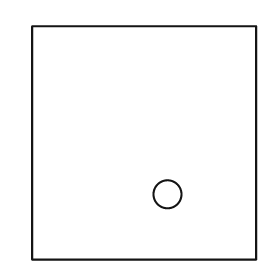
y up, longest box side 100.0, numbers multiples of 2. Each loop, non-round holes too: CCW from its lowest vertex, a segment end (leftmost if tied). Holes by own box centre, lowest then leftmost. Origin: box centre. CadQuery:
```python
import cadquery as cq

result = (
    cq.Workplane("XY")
    .moveTo(-48.0, -50.0)
    .lineTo(48.0, -50.0)
    .lineTo(48.0, 50.0)
    .lineTo(-48.0, 50.0)
    .close()
    .moveTo(10.0, -22.0)
    .circle(6.0)
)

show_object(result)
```